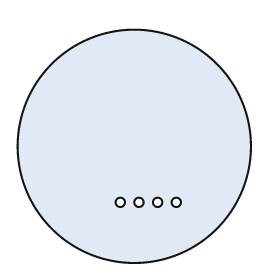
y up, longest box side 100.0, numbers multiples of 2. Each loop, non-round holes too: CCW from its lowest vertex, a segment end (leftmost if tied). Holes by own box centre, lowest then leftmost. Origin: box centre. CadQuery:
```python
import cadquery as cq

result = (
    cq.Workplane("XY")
    .moveTo(0.0, 0.0)
    .circle(50.0)
    .moveTo(-6.0, -24.0)
    .circle(2.0)
    .moveTo(2.0, -24.0)
    .circle(2.0)
    .moveTo(10.0, -24.0)
    .circle(2.0)
    .moveTo(18.0, -24.0)
    .circle(2.0)
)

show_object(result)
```